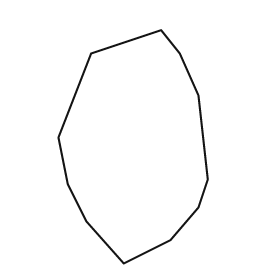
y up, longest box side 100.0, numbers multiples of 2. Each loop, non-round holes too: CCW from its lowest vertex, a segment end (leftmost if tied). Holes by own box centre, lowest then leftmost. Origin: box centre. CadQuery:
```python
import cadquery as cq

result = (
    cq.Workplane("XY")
    .moveTo(-4.0, -50.0)
    .lineTo(16.0, -40.0)
    .lineTo(28.0, -26.0)
    .lineTo(32.0, -14.0)
    .lineTo(28.0, 22.0)
    .lineTo(20.0, 40.0)
    .lineTo(12.0, 50.0)
    .lineTo(-18.0, 40.0)
    .lineTo(-32.0, 4.0)
    .lineTo(-28.0, -16.0)
    .lineTo(-20.0, -32.0)
    .close()
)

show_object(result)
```